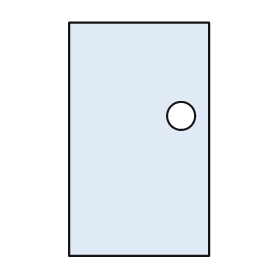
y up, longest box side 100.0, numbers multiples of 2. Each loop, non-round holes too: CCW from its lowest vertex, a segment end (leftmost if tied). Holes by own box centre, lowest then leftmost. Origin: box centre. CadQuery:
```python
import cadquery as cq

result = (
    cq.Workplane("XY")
    .moveTo(-30.0, -50.0)
    .lineTo(30.0, -50.0)
    .lineTo(30.0, 50.0)
    .lineTo(-30.0, 50.0)
    .close()
    .moveTo(18.0, 10.0)
    .circle(6.0)
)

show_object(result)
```